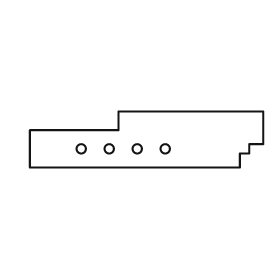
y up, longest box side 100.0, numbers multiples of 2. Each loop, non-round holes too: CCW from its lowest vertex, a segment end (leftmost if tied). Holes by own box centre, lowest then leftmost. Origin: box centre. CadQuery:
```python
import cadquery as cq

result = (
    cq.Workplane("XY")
    .moveTo(-50.0, -12.0)
    .lineTo(40.0, -12.0)
    .lineTo(40.0, -6.0)
    .lineTo(44.0, -6.0)
    .lineTo(44.0, -2.0)
    .lineTo(50.0, -2.0)
    .lineTo(50.0, 12.0)
    .lineTo(-12.0, 12.0)
    .lineTo(-12.0, 4.0)
    .lineTo(-50.0, 4.0)
    .close()
    .moveTo(-28.0, -4.0)
    .circle(2.0)
    .moveTo(-16.0, -4.0)
    .circle(2.0)
    .moveTo(-4.0, -4.0)
    .circle(2.0)
    .moveTo(8.0, -4.0)
    .circle(2.0)
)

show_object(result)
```